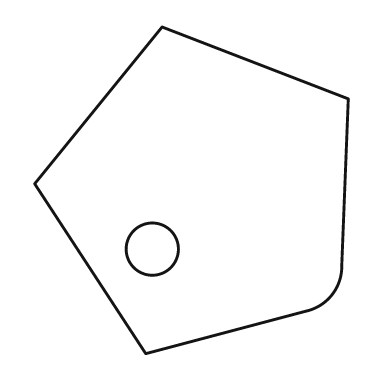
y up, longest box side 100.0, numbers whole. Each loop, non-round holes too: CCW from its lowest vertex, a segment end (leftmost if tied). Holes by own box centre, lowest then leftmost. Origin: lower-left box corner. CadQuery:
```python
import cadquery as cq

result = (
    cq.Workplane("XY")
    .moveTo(34.0, 0.0)
    .lineTo(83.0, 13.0)
    .threePointArc((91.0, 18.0), (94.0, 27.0))
    .lineTo(96.0, 78.0)
    .lineTo(39.0, 100.0)
    .lineTo(0.0, 52.0)
    .close()
    .moveTo(36.0, 32.0)
    .circle(8.0)
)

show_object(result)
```